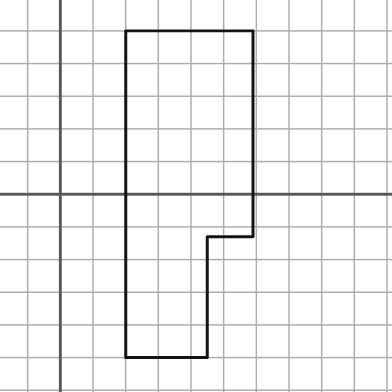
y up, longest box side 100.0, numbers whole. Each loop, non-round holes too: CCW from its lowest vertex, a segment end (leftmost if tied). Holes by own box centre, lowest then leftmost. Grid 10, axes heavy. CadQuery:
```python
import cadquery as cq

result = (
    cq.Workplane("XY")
    .moveTo(20.0, -50.0)
    .lineTo(45.0, -50.0)
    .lineTo(45.0, -13.0)
    .lineTo(59.0, -13.0)
    .lineTo(59.0, 50.0)
    .lineTo(20.0, 50.0)
    .close()
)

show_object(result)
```